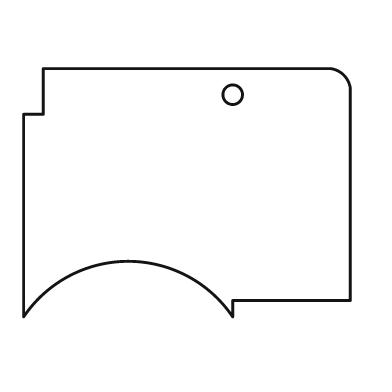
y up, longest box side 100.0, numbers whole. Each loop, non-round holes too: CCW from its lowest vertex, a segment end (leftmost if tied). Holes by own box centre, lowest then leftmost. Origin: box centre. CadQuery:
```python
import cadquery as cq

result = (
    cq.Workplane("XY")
    .moveTo(-50.0, -38.0)
    .threePointArc((-18.0, -21.0), (14.0, -38.0))
    .lineTo(14.0, -33.0)
    .lineTo(50.0, -33.0)
    .lineTo(50.0, 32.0)
    .threePointArc((48.0, 36.0), (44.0, 38.0))
    .lineTo(-44.0, 38.0)
    .lineTo(-44.0, 24.0)
    .lineTo(-50.0, 24.0)
    .close()
    .moveTo(14.0, 30.0)
    .circle(3.0)
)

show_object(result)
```